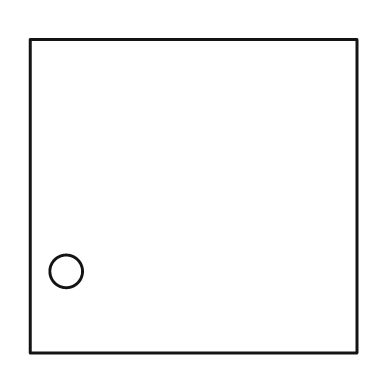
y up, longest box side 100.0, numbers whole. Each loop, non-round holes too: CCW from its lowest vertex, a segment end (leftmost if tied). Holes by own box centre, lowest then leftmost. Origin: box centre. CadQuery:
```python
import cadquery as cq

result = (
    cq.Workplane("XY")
    .moveTo(-50.0, -48.0)
    .lineTo(50.0, -48.0)
    .lineTo(50.0, 48.0)
    .lineTo(-50.0, 48.0)
    .close()
    .moveTo(-39.0, -23.0)
    .circle(5.0)
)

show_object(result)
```